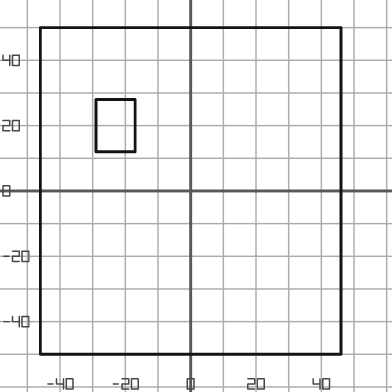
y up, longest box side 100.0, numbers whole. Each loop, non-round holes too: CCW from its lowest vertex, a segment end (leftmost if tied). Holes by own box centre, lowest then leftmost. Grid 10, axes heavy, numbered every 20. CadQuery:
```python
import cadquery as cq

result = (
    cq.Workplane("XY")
    .moveTo(-46.0, -50.0)
    .lineTo(46.0, -50.0)
    .lineTo(46.0, 50.0)
    .lineTo(-46.0, 50.0)
    .close()
    .moveTo(-29.0, 12.0)
    .lineTo(-17.0, 12.0)
    .lineTo(-17.0, 28.0)
    .lineTo(-29.0, 28.0)
    .close()
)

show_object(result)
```